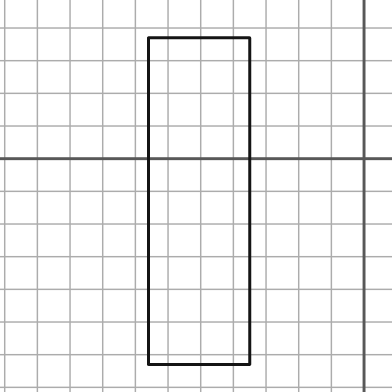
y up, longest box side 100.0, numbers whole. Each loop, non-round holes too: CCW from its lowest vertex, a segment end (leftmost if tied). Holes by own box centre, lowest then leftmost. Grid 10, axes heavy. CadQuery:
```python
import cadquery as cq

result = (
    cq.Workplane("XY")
    .moveTo(-66.0, -63.0)
    .lineTo(-35.0, -63.0)
    .lineTo(-35.0, 37.0)
    .lineTo(-66.0, 37.0)
    .close()
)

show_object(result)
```